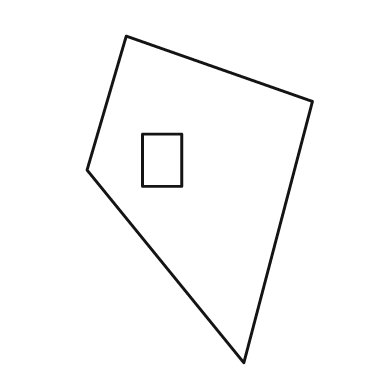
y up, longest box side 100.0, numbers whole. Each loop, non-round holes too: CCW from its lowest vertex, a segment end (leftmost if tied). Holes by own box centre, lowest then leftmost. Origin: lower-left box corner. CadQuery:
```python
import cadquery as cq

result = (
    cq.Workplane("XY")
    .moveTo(48.0, 0.0)
    .lineTo(69.0, 80.0)
    .lineTo(12.0, 100.0)
    .lineTo(0.0, 59.0)
    .close()
    .moveTo(17.0, 54.0)
    .lineTo(29.0, 54.0)
    .lineTo(29.0, 70.0)
    .lineTo(17.0, 70.0)
    .close()
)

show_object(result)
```